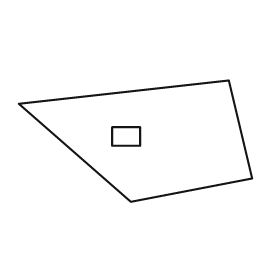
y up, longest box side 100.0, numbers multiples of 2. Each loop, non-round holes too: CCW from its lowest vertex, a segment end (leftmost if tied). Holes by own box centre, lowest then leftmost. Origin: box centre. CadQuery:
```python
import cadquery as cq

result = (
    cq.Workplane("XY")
    .moveTo(-2.0, -26.0)
    .lineTo(50.0, -16.0)
    .lineTo(40.0, 26.0)
    .lineTo(-50.0, 16.0)
    .close()
    .moveTo(-10.0, -2.0)
    .lineTo(2.0, -2.0)
    .lineTo(2.0, 6.0)
    .lineTo(-10.0, 6.0)
    .close()
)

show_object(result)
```